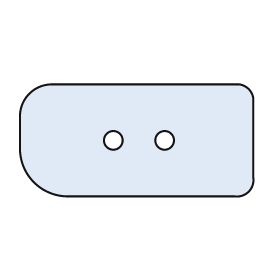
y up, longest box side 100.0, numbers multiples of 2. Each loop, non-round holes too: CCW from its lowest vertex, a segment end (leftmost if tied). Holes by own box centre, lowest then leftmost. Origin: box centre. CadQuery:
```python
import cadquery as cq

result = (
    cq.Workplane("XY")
    .moveTo(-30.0, -24.0)
    .lineTo(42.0, -24.0)
    .threePointArc((48.0, -22.0), (50.0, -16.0))
    .lineTo(50.0, 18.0)
    .threePointArc((48.0, 22.0), (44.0, 24.0))
    .lineTo(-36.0, 24.0)
    .threePointArc((-46.0, 20.0), (-50.0, 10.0))
    .lineTo(-50.0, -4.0)
    .threePointArc((-44.0, -18.0), (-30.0, -24.0))
    .close()
    .moveTo(-10.0, 0.0)
    .circle(4.0)
    .moveTo(12.0, 0.0)
    .circle(4.0)
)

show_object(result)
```